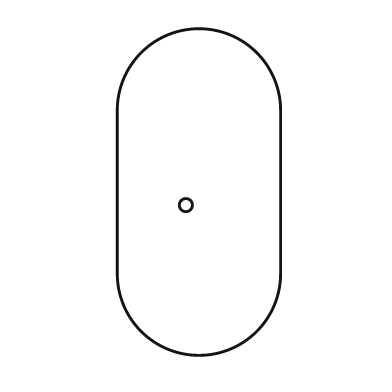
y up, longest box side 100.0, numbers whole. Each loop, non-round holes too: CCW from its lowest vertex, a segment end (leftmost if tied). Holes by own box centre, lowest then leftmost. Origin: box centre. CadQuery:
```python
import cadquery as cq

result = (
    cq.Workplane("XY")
    .moveTo(-25.0, -25.0)
    .threePointArc((0.0, -50.0), (25.0, -25.0))
    .lineTo(25.0, 25.0)
    .threePointArc((0.0, 50.0), (-25.0, 25.0))
    .close()
    .moveTo(-4.0, -4.0)
    .circle(2.0)
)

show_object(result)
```